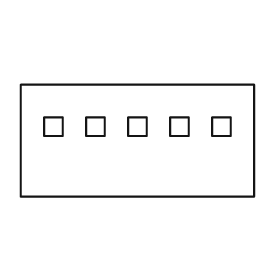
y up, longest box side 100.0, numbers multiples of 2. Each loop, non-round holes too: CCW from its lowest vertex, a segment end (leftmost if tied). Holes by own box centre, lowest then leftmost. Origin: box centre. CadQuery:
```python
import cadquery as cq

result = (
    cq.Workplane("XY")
    .moveTo(-50.0, -24.0)
    .lineTo(50.0, -24.0)
    .lineTo(50.0, 24.0)
    .lineTo(-50.0, 24.0)
    .close()
    .moveTo(-40.0, 2.0)
    .lineTo(-32.0, 2.0)
    .lineTo(-32.0, 10.0)
    .lineTo(-40.0, 10.0)
    .close()
    .moveTo(-22.0, 2.0)
    .lineTo(-14.0, 2.0)
    .lineTo(-14.0, 10.0)
    .lineTo(-22.0, 10.0)
    .close()
    .moveTo(-4.0, 2.0)
    .lineTo(4.0, 2.0)
    .lineTo(4.0, 10.0)
    .lineTo(-4.0, 10.0)
    .close()
    .moveTo(14.0, 2.0)
    .lineTo(22.0, 2.0)
    .lineTo(22.0, 10.0)
    .lineTo(14.0, 10.0)
    .close()
    .moveTo(32.0, 2.0)
    .lineTo(40.0, 2.0)
    .lineTo(40.0, 10.0)
    .lineTo(32.0, 10.0)
    .close()
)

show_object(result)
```